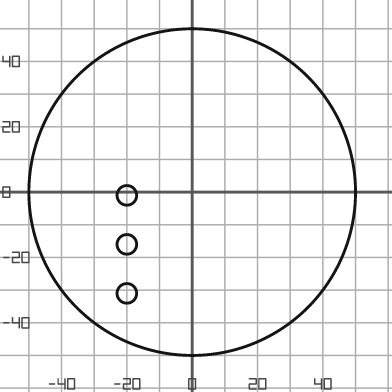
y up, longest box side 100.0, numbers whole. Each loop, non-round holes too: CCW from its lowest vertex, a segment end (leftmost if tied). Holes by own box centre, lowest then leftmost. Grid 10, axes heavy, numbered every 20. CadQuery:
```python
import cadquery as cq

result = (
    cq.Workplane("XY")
    .moveTo(0.0, 0.0)
    .circle(50.0)
    .moveTo(-20.0, -31.0)
    .circle(3.0)
    .moveTo(-20.0, -16.0)
    .circle(3.0)
    .moveTo(-20.0, -1.0)
    .circle(3.0)
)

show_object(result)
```